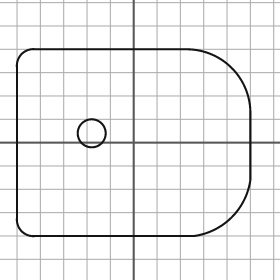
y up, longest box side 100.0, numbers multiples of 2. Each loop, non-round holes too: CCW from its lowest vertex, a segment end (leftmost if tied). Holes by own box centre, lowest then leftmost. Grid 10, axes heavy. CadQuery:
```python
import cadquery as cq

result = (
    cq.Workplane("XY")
    .moveTo(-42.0, -40.0)
    .lineTo(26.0, -40.0)
    .threePointArc((42.0, -32.0), (50.0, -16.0))
    .lineTo(50.0, 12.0)
    .threePointArc((42.0, 32.0), (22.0, 40.0))
    .lineTo(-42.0, 40.0)
    .threePointArc((-48.0, 38.0), (-50.0, 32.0))
    .lineTo(-50.0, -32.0)
    .threePointArc((-48.0, -38.0), (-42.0, -40.0))
    .close()
    .moveTo(-18.0, 4.0)
    .circle(6.0)
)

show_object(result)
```